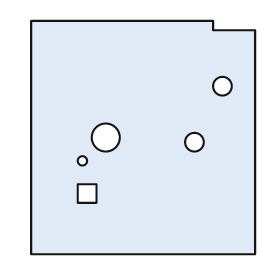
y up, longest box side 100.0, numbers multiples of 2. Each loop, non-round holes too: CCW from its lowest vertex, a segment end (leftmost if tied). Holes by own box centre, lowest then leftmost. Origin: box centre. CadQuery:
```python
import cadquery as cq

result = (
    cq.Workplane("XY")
    .moveTo(-48.0, -50.0)
    .lineTo(48.0, -50.0)
    .lineTo(48.0, 46.0)
    .lineTo(30.0, 46.0)
    .lineTo(30.0, 50.0)
    .lineTo(-48.0, 50.0)
    .close()
    .moveTo(-28.0, -28.0)
    .lineTo(-20.0, -28.0)
    .lineTo(-20.0, -20.0)
    .lineTo(-28.0, -20.0)
    .close()
    .moveTo(-26.0, -10.0)
    .circle(2.0)
    .moveTo(22.0, -2.0)
    .circle(4.0)
    .moveTo(-16.0, 0.0)
    .circle(6.0)
    .moveTo(34.0, 22.0)
    .circle(4.0)
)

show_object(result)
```